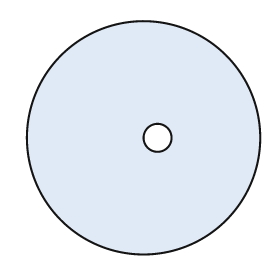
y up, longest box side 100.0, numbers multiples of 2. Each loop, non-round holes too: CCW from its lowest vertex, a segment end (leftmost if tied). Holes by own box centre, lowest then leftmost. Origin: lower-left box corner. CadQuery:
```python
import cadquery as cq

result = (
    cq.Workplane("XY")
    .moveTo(50.0, 50.0)
    .circle(50.0)
    .moveTo(56.0, 50.0)
    .circle(6.0)
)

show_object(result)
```